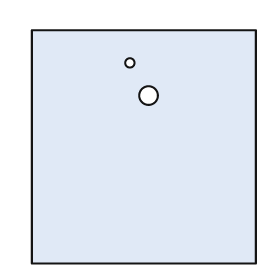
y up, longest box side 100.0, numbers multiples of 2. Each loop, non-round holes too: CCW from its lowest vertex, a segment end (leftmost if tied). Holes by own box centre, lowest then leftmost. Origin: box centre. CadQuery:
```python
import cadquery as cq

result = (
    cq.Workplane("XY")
    .moveTo(-48.0, -50.0)
    .lineTo(48.0, -50.0)
    .lineTo(48.0, 50.0)
    .lineTo(-48.0, 50.0)
    .close()
    .moveTo(2.0, 22.0)
    .circle(4.0)
    .moveTo(-6.0, 36.0)
    .circle(2.0)
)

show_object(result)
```